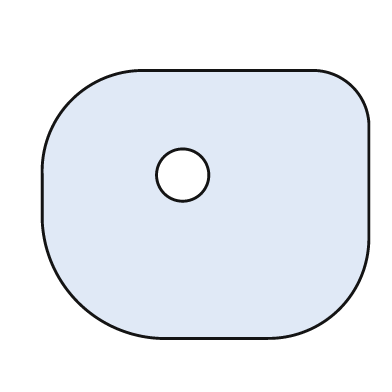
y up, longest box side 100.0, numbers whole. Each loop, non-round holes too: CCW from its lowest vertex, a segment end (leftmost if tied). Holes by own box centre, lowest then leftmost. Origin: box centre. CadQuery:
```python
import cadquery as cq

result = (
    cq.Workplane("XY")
    .moveTo(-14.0, -41.0)
    .lineTo(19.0, -41.0)
    .threePointArc((41.0, -32.0), (50.0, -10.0))
    .lineTo(50.0, 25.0)
    .threePointArc((45.0, 36.0), (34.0, 41.0))
    .lineTo(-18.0, 41.0)
    .threePointArc((-41.0, 32.0), (-50.0, 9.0))
    .lineTo(-50.0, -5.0)
    .threePointArc((-39.0, -30.0), (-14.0, -41.0))
    .close()
    .moveTo(-7.0, 9.0)
    .circle(8.0)
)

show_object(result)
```